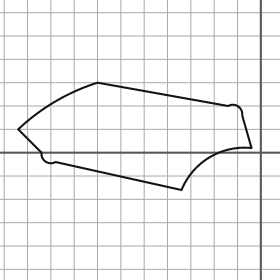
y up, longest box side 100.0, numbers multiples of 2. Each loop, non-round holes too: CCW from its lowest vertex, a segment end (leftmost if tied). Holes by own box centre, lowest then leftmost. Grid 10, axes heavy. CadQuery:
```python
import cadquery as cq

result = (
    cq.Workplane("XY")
    .moveTo(-34.0, -16.0)
    .threePointArc((-22.0, -2.0), (-4.0, 2.0))
    .lineTo(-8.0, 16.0)
    .threePointArc((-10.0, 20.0), (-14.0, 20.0))
    .lineTo(-70.0, 30.0)
    .threePointArc((-88.0, 22.0), (-104.0, 10.0))
    .lineTo(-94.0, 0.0)
    .threePointArc((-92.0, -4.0), (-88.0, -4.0))
    .close()
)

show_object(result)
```